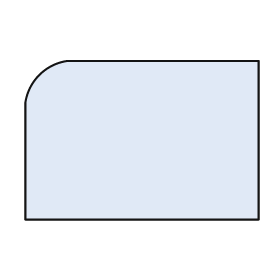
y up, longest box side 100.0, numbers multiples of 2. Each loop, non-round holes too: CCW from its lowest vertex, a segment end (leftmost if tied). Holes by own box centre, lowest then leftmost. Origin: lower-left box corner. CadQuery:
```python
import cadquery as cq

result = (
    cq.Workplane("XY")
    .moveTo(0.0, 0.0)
    .lineTo(100.0, 0.0)
    .lineTo(100.0, 68.0)
    .lineTo(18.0, 68.0)
    .threePointArc((6.0, 62.0), (0.0, 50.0))
    .close()
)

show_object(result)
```